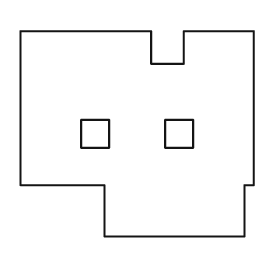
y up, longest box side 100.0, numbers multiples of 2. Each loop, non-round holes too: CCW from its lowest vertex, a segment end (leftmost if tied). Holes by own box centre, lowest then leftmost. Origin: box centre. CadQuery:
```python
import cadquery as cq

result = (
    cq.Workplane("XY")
    .moveTo(-14.0, -44.0)
    .lineTo(46.0, -44.0)
    .lineTo(46.0, -22.0)
    .lineTo(50.0, -22.0)
    .lineTo(50.0, 44.0)
    .lineTo(20.0, 44.0)
    .lineTo(20.0, 30.0)
    .lineTo(6.0, 30.0)
    .lineTo(6.0, 44.0)
    .lineTo(-50.0, 44.0)
    .lineTo(-50.0, -22.0)
    .lineTo(-14.0, -22.0)
    .close()
    .moveTo(-24.0, -6.0)
    .lineTo(-12.0, -6.0)
    .lineTo(-12.0, 6.0)
    .lineTo(-24.0, 6.0)
    .close()
    .moveTo(12.0, -6.0)
    .lineTo(24.0, -6.0)
    .lineTo(24.0, 6.0)
    .lineTo(12.0, 6.0)
    .close()
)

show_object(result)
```